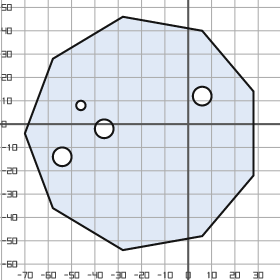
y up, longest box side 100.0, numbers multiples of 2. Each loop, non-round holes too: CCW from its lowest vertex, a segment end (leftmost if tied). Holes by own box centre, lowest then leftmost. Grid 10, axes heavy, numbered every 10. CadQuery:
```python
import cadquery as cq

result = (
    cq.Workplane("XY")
    .moveTo(-28.0, -54.0)
    .lineTo(6.0, -48.0)
    .lineTo(28.0, -22.0)
    .lineTo(28.0, 14.0)
    .lineTo(6.0, 40.0)
    .lineTo(-28.0, 46.0)
    .lineTo(-58.0, 28.0)
    .lineTo(-70.0, -4.0)
    .lineTo(-58.0, -36.0)
    .close()
    .moveTo(-54.0, -14.0)
    .circle(4.0)
    .moveTo(-36.0, -2.0)
    .circle(4.0)
    .moveTo(-46.0, 8.0)
    .circle(2.0)
    .moveTo(6.0, 12.0)
    .circle(4.0)
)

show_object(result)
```